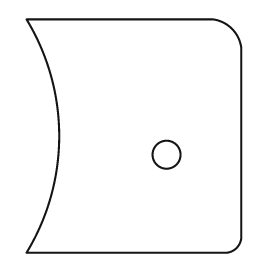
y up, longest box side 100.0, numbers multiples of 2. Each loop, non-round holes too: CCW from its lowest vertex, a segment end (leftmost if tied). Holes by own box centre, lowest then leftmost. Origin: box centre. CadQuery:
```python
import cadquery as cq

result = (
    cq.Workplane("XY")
    .moveTo(-46.0, -50.0)
    .lineTo(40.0, -50.0)
    .threePointArc((44.0, -48.0), (46.0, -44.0))
    .lineTo(46.0, 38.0)
    .threePointArc((42.0, 46.0), (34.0, 50.0))
    .lineTo(-46.0, 50.0)
    .threePointArc((-32.0, 0.0), (-46.0, -50.0))
    .close()
    .moveTo(14.0, -8.0)
    .circle(6.0)
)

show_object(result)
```